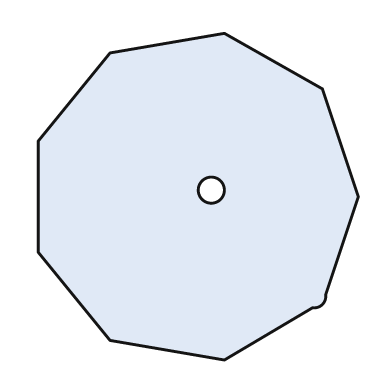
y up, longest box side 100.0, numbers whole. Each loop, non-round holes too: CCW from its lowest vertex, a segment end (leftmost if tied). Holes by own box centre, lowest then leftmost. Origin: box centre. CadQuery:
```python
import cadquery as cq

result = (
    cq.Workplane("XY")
    .moveTo(8.0, -50.0)
    .lineTo(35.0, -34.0)
    .threePointArc((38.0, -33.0), (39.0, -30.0))
    .lineTo(49.0, 0.0)
    .lineTo(38.0, 33.0)
    .lineTo(8.0, 50.0)
    .lineTo(-27.0, 44.0)
    .lineTo(-49.0, 17.0)
    .lineTo(-49.0, -17.0)
    .lineTo(-27.0, -44.0)
    .close()
    .moveTo(4.0, 2.0)
    .circle(4.0)
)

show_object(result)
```